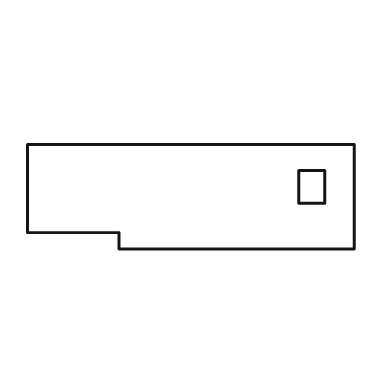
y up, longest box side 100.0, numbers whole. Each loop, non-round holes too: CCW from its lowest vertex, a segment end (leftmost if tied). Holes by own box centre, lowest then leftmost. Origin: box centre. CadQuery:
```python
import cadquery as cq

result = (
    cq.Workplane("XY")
    .moveTo(-22.0, -16.0)
    .lineTo(50.0, -16.0)
    .lineTo(50.0, 16.0)
    .lineTo(-50.0, 16.0)
    .lineTo(-50.0, -11.0)
    .lineTo(-22.0, -11.0)
    .close()
    .moveTo(33.0, -2.0)
    .lineTo(41.0, -2.0)
    .lineTo(41.0, 8.0)
    .lineTo(33.0, 8.0)
    .close()
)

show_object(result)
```